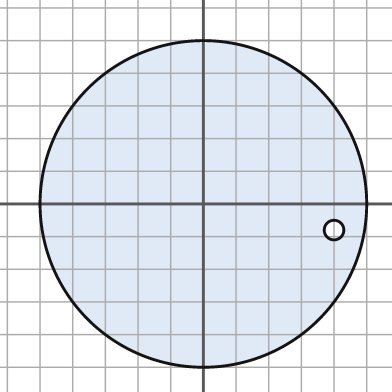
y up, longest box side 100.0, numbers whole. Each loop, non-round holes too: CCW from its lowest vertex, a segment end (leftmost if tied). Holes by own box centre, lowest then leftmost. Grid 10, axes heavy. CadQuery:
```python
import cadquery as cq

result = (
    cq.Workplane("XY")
    .moveTo(0.0, 0.0)
    .circle(50.0)
    .moveTo(40.0, -8.0)
    .circle(3.0)
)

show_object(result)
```